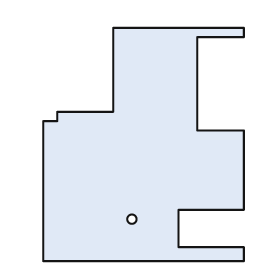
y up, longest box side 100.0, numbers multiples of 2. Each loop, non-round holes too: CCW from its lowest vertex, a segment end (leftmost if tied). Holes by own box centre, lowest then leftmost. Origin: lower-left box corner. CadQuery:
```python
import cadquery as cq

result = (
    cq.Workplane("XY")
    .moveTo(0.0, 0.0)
    .lineTo(86.0, 0.0)
    .lineTo(86.0, 6.0)
    .lineTo(58.0, 6.0)
    .lineTo(58.0, 22.0)
    .lineTo(86.0, 22.0)
    .lineTo(86.0, 56.0)
    .lineTo(66.0, 56.0)
    .lineTo(66.0, 96.0)
    .lineTo(86.0, 96.0)
    .lineTo(86.0, 100.0)
    .lineTo(30.0, 100.0)
    .lineTo(30.0, 64.0)
    .lineTo(6.0, 64.0)
    .lineTo(6.0, 60.0)
    .lineTo(0.0, 60.0)
    .close()
    .moveTo(38.0, 18.0)
    .circle(2.0)
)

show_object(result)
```